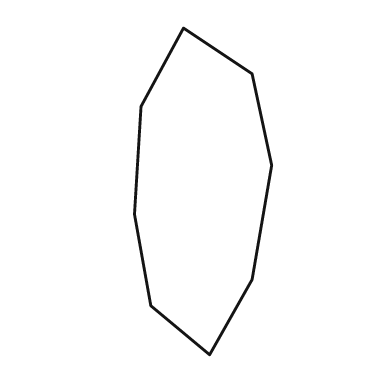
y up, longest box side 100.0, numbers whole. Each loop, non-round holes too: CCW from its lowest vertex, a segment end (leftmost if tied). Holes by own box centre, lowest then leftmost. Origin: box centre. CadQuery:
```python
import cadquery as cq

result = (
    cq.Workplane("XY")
    .moveTo(2.0, -50.0)
    .lineTo(15.0, -27.0)
    .lineTo(21.0, 8.0)
    .lineTo(15.0, 36.0)
    .lineTo(-6.0, 50.0)
    .lineTo(-19.0, 26.0)
    .lineTo(-21.0, -7.0)
    .lineTo(-16.0, -35.0)
    .close()
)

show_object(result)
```